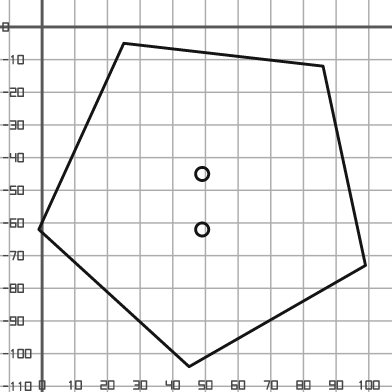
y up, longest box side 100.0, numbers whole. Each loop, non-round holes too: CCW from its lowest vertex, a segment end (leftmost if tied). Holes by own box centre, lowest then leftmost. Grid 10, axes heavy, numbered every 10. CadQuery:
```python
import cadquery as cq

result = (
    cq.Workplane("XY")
    .moveTo(45.0, -104.0)
    .lineTo(99.0, -73.0)
    .lineTo(86.0, -12.0)
    .lineTo(25.0, -5.0)
    .lineTo(-1.0, -62.0)
    .close()
    .moveTo(49.0, -62.0)
    .circle(2.0)
    .moveTo(49.0, -45.0)
    .circle(2.0)
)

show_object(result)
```